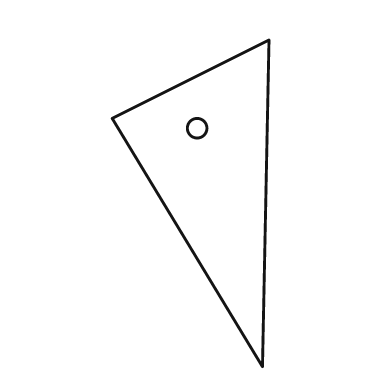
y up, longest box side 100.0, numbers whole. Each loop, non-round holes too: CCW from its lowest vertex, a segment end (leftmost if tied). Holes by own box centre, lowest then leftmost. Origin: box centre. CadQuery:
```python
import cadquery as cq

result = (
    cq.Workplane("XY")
    .moveTo(22.0, -50.0)
    .lineTo(24.0, 50.0)
    .lineTo(-24.0, 26.0)
    .close()
    .moveTo(2.0, 23.0)
    .circle(3.0)
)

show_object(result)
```